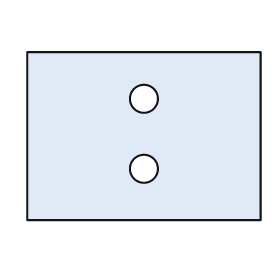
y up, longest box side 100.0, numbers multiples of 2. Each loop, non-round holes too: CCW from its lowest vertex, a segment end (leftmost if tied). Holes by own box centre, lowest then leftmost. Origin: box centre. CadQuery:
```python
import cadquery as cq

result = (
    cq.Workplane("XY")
    .moveTo(-50.0, -36.0)
    .lineTo(50.0, -36.0)
    .lineTo(50.0, 36.0)
    .lineTo(-50.0, 36.0)
    .close()
    .moveTo(0.0, -14.0)
    .circle(6.0)
    .moveTo(0.0, 16.0)
    .circle(6.0)
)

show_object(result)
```